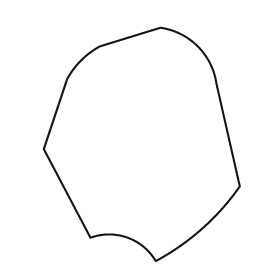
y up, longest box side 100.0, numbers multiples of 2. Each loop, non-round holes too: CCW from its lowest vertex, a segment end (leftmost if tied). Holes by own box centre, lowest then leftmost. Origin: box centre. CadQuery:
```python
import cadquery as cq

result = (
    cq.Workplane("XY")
    .moveTo(6.0, -50.0)
    .threePointArc((26.0, -36.0), (42.0, -18.0))
    .lineTo(32.0, 26.0)
    .threePointArc((24.0, 42.0), (8.0, 50.0))
    .lineTo(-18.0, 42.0)
    .threePointArc((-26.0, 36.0), (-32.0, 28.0))
    .lineTo(-42.0, -2.0)
    .lineTo(-22.0, -40.0)
    .threePointArc((-6.0, -40.0), (6.0, -50.0))
    .close()
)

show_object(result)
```